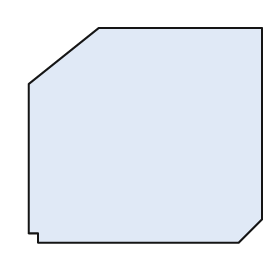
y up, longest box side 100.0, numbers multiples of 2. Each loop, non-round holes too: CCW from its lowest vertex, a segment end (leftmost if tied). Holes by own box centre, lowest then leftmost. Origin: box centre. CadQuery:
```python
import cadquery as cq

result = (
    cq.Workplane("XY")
    .moveTo(-46.0, -46.0)
    .lineTo(40.0, -46.0)
    .lineTo(50.0, -36.0)
    .lineTo(50.0, 46.0)
    .lineTo(-20.0, 46.0)
    .lineTo(-50.0, 22.0)
    .lineTo(-50.0, -42.0)
    .lineTo(-46.0, -42.0)
    .close()
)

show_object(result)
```